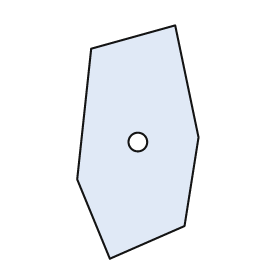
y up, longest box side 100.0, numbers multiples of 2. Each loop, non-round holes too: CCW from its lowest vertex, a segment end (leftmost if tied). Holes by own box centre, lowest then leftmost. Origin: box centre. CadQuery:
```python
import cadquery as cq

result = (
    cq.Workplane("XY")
    .moveTo(-12.0, -50.0)
    .lineTo(20.0, -36.0)
    .lineTo(26.0, 2.0)
    .lineTo(16.0, 50.0)
    .lineTo(-20.0, 40.0)
    .lineTo(-26.0, -16.0)
    .close()
    .moveTo(0.0, 0.0)
    .circle(4.0)
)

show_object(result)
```